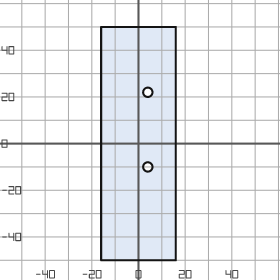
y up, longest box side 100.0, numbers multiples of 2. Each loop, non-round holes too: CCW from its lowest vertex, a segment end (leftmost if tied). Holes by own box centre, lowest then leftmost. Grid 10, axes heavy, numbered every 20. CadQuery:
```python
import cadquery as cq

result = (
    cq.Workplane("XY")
    .moveTo(-16.0, -50.0)
    .lineTo(16.0, -50.0)
    .lineTo(16.0, 50.0)
    .lineTo(-16.0, 50.0)
    .close()
    .moveTo(4.0, -10.0)
    .circle(2.0)
    .moveTo(4.0, 22.0)
    .circle(2.0)
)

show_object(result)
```